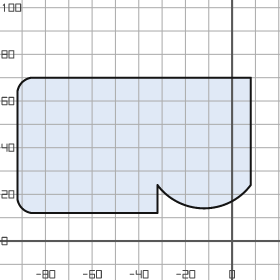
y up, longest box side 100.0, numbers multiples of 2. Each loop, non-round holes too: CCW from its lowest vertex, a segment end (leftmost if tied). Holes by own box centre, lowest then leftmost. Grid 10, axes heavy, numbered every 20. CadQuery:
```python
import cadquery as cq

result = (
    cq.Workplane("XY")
    .moveTo(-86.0, 12.0)
    .lineTo(-32.0, 12.0)
    .lineTo(-32.0, 24.0)
    .threePointArc((-12.0, 14.0), (8.0, 24.0))
    .lineTo(8.0, 70.0)
    .lineTo(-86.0, 70.0)
    .threePointArc((-90.0, 68.0), (-92.0, 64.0))
    .lineTo(-92.0, 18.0)
    .threePointArc((-90.0, 14.0), (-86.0, 12.0))
    .close()
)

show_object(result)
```